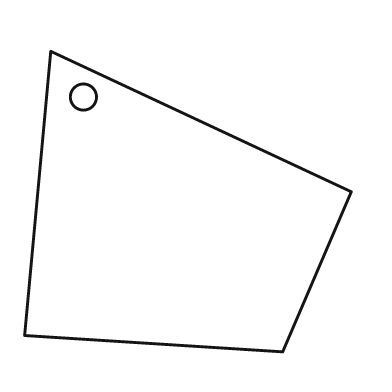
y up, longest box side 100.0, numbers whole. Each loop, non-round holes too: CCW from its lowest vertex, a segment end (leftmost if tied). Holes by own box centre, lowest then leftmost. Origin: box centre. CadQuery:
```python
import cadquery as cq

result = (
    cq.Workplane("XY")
    .moveTo(29.0, -46.0)
    .lineTo(50.0, 3.0)
    .lineTo(-42.0, 46.0)
    .lineTo(-50.0, -41.0)
    .close()
    .moveTo(-32.0, 32.0)
    .circle(4.0)
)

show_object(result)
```